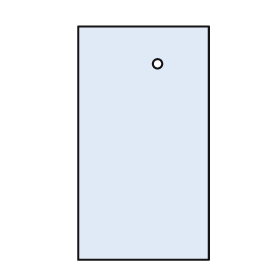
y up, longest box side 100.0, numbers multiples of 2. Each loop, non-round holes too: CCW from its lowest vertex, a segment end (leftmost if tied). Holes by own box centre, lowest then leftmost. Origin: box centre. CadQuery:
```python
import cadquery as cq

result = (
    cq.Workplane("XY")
    .moveTo(-28.0, -50.0)
    .lineTo(28.0, -50.0)
    .lineTo(28.0, 50.0)
    .lineTo(-28.0, 50.0)
    .close()
    .moveTo(6.0, 34.0)
    .circle(2.0)
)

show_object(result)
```